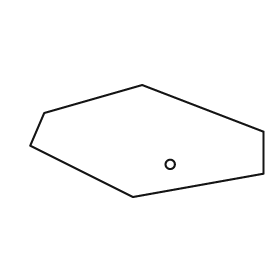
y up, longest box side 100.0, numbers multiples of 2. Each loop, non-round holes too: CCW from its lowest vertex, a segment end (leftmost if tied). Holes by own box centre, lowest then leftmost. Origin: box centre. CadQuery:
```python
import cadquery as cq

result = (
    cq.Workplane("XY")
    .moveTo(-6.0, -24.0)
    .lineTo(50.0, -14.0)
    .lineTo(50.0, 4.0)
    .lineTo(-2.0, 24.0)
    .lineTo(-44.0, 12.0)
    .lineTo(-50.0, -2.0)
    .close()
    .moveTo(10.0, -10.0)
    .circle(2.0)
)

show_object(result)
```